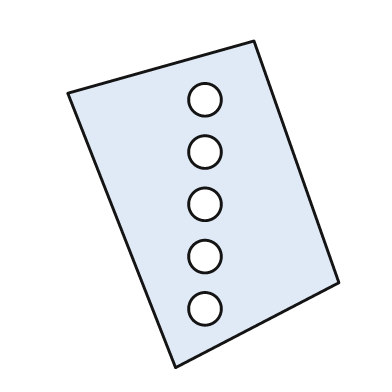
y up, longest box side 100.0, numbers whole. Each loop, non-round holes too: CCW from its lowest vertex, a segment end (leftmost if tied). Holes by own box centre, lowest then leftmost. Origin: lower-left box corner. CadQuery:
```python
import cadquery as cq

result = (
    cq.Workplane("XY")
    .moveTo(33.0, 0.0)
    .lineTo(83.0, 26.0)
    .lineTo(57.0, 100.0)
    .lineTo(0.0, 84.0)
    .close()
    .moveTo(42.0, 18.0)
    .circle(5.0)
    .moveTo(42.0, 34.0)
    .circle(5.0)
    .moveTo(42.0, 50.0)
    .circle(5.0)
    .moveTo(42.0, 66.0)
    .circle(5.0)
    .moveTo(42.0, 82.0)
    .circle(5.0)
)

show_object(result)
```